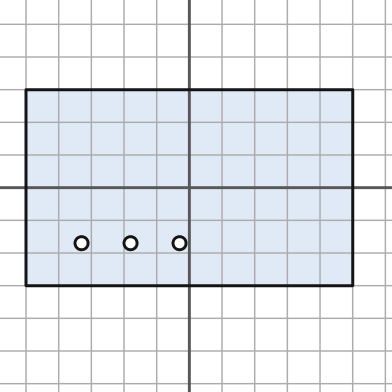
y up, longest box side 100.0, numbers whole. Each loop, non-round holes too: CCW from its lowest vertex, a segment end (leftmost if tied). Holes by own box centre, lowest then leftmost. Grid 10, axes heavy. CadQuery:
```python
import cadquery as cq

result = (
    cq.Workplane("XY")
    .moveTo(-50.0, -30.0)
    .lineTo(50.0, -30.0)
    .lineTo(50.0, 30.0)
    .lineTo(-50.0, 30.0)
    .close()
    .moveTo(-33.0, -17.0)
    .circle(2.0)
    .moveTo(-18.0, -17.0)
    .circle(2.0)
    .moveTo(-3.0, -17.0)
    .circle(2.0)
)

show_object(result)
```